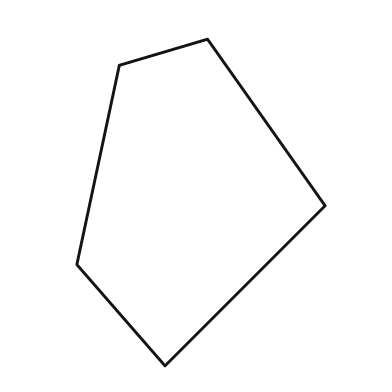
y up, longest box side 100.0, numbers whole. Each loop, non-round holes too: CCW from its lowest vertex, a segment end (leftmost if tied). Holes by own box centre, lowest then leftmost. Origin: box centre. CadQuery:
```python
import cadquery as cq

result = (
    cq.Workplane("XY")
    .moveTo(-11.0, -50.0)
    .lineTo(38.0, -1.0)
    .lineTo(2.0, 50.0)
    .lineTo(-25.0, 42.0)
    .lineTo(-38.0, -19.0)
    .close()
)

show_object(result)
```